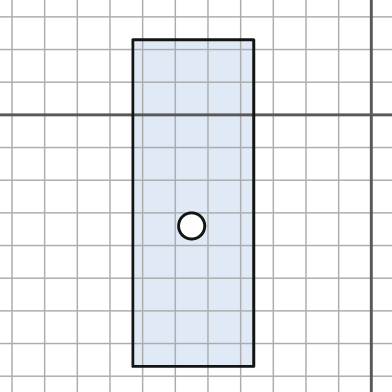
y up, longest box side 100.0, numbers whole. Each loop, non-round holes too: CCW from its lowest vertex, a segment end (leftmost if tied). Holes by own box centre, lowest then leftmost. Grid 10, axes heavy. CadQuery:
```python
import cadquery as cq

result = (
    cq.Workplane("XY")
    .moveTo(-73.0, -77.0)
    .lineTo(-36.0, -77.0)
    .lineTo(-36.0, 23.0)
    .lineTo(-73.0, 23.0)
    .close()
    .moveTo(-55.0, -34.0)
    .circle(4.0)
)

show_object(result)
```